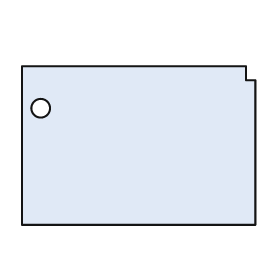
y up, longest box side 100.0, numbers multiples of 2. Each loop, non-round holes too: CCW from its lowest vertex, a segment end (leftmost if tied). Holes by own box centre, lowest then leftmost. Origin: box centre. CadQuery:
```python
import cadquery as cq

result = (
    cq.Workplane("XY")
    .moveTo(-50.0, -34.0)
    .lineTo(50.0, -34.0)
    .lineTo(50.0, 28.0)
    .lineTo(46.0, 28.0)
    .lineTo(46.0, 34.0)
    .lineTo(-50.0, 34.0)
    .close()
    .moveTo(-42.0, 16.0)
    .circle(4.0)
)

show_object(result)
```